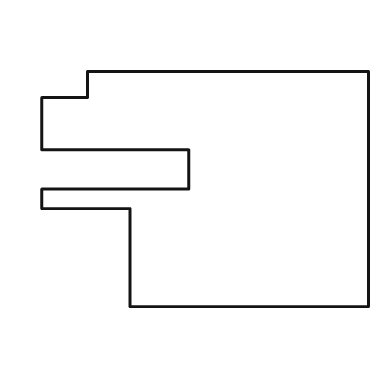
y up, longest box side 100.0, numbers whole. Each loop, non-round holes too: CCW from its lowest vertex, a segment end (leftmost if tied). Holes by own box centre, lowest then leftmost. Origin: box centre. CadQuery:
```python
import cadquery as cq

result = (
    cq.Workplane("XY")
    .moveTo(-23.0, -36.0)
    .lineTo(50.0, -36.0)
    .lineTo(50.0, 36.0)
    .lineTo(-36.0, 36.0)
    .lineTo(-36.0, 28.0)
    .lineTo(-50.0, 28.0)
    .lineTo(-50.0, 12.0)
    .lineTo(-5.0, 12.0)
    .lineTo(-5.0, 0.0)
    .lineTo(-50.0, 0.0)
    .lineTo(-50.0, -6.0)
    .lineTo(-23.0, -6.0)
    .close()
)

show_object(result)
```